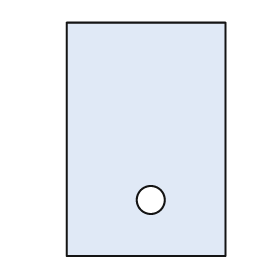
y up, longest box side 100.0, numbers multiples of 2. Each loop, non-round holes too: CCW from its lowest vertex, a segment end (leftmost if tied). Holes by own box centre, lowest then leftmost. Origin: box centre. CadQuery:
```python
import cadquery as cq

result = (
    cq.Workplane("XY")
    .moveTo(-34.0, -50.0)
    .lineTo(34.0, -50.0)
    .lineTo(34.0, 50.0)
    .lineTo(-34.0, 50.0)
    .close()
    .moveTo(2.0, -26.0)
    .circle(6.0)
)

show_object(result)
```